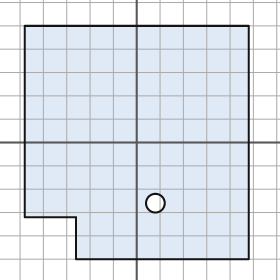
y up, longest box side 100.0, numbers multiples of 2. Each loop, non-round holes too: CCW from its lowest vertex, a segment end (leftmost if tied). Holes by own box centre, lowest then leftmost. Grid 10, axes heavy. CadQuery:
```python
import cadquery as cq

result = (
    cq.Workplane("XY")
    .moveTo(-26.0, -50.0)
    .lineTo(48.0, -50.0)
    .lineTo(48.0, 50.0)
    .lineTo(-48.0, 50.0)
    .lineTo(-48.0, -32.0)
    .lineTo(-26.0, -32.0)
    .close()
    .moveTo(8.0, -26.0)
    .circle(4.0)
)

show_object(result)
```